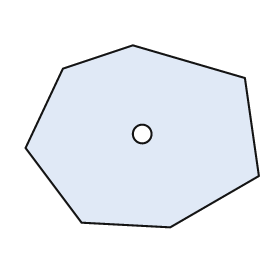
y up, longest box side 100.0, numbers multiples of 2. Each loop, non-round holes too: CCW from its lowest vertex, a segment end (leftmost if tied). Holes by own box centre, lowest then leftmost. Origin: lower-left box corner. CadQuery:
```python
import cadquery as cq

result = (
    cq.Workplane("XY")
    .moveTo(62.0, 0.0)
    .lineTo(100.0, 22.0)
    .lineTo(94.0, 64.0)
    .lineTo(46.0, 78.0)
    .lineTo(16.0, 68.0)
    .lineTo(0.0, 34.0)
    .lineTo(24.0, 2.0)
    .close()
    .moveTo(50.0, 40.0)
    .circle(4.0)
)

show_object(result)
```